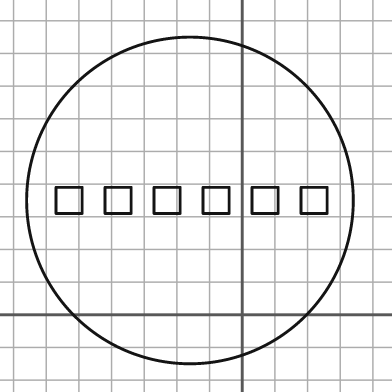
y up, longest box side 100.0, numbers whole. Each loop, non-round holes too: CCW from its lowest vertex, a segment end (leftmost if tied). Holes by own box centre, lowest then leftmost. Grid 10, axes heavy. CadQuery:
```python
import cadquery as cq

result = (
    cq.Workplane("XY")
    .moveTo(-16.0, 35.0)
    .circle(50.0)
    .moveTo(-57.0, 31.0)
    .lineTo(-49.0, 31.0)
    .lineTo(-49.0, 39.0)
    .lineTo(-57.0, 39.0)
    .close()
    .moveTo(-42.0, 31.0)
    .lineTo(-34.0, 31.0)
    .lineTo(-34.0, 39.0)
    .lineTo(-42.0, 39.0)
    .close()
    .moveTo(-27.0, 31.0)
    .lineTo(-19.0, 31.0)
    .lineTo(-19.0, 39.0)
    .lineTo(-27.0, 39.0)
    .close()
    .moveTo(-12.0, 31.0)
    .lineTo(-4.0, 31.0)
    .lineTo(-4.0, 39.0)
    .lineTo(-12.0, 39.0)
    .close()
    .moveTo(3.0, 31.0)
    .lineTo(11.0, 31.0)
    .lineTo(11.0, 39.0)
    .lineTo(3.0, 39.0)
    .close()
    .moveTo(18.0, 31.0)
    .lineTo(26.0, 31.0)
    .lineTo(26.0, 39.0)
    .lineTo(18.0, 39.0)
    .close()
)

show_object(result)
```